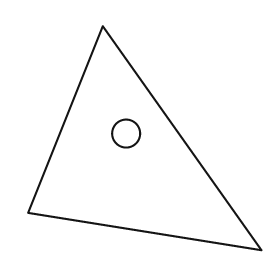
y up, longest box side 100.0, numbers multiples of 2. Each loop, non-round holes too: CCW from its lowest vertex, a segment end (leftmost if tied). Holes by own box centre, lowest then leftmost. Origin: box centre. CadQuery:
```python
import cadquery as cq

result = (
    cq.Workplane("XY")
    .moveTo(50.0, -48.0)
    .lineTo(-18.0, 48.0)
    .lineTo(-50.0, -32.0)
    .close()
    .moveTo(-8.0, 2.0)
    .circle(6.0)
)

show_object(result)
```